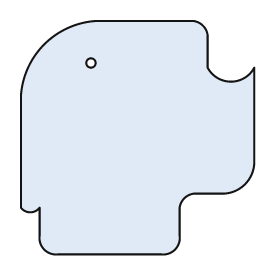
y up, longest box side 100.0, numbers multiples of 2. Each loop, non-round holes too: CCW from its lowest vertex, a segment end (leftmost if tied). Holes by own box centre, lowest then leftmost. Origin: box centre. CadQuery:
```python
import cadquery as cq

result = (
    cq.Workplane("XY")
    .moveTo(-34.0, -50.0)
    .lineTo(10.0, -50.0)
    .threePointArc((16.0, -48.0), (18.0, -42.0))
    .lineTo(18.0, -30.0)
    .threePointArc((20.0, -26.0), (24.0, -24.0))
    .lineTo(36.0, -24.0)
    .threePointArc((46.0, -20.0), (50.0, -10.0))
    .lineTo(50.0, 30.0)
    .threePointArc((40.0, 24.0), (30.0, 30.0))
    .lineTo(30.0, 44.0)
    .threePointArc((28.0, 48.0), (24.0, 50.0))
    .lineTo(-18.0, 50.0)
    .threePointArc((-40.0, 40.0), (-50.0, 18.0))
    .lineTo(-50.0, -30.0)
    .threePointArc((-46.0, -32.0), (-42.0, -30.0))
    .lineTo(-42.0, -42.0)
    .threePointArc((-40.0, -48.0), (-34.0, -50.0))
    .close()
    .moveTo(-20.0, 32.0)
    .circle(2.0)
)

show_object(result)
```